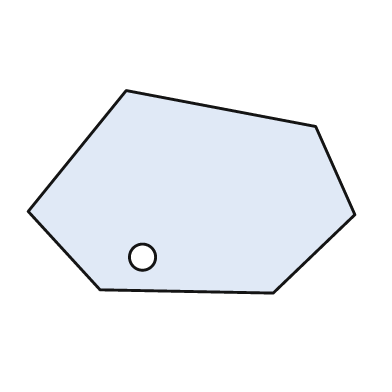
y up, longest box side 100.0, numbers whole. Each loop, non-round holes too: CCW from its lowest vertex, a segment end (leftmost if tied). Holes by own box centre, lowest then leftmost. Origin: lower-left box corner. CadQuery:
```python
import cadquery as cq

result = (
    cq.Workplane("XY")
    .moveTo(75.0, 0.0)
    .lineTo(100.0, 24.0)
    .lineTo(88.0, 51.0)
    .lineTo(30.0, 62.0)
    .lineTo(0.0, 25.0)
    .lineTo(22.0, 1.0)
    .close()
    .moveTo(35.0, 11.0)
    .circle(4.0)
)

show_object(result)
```